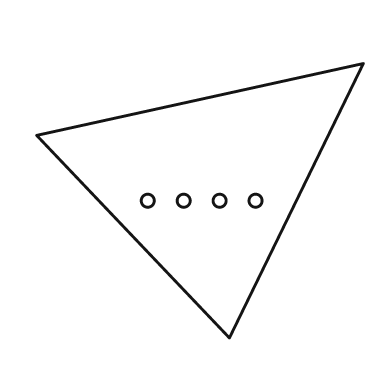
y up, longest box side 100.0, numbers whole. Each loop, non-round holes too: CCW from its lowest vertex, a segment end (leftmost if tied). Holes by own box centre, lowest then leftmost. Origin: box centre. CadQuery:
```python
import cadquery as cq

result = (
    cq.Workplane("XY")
    .moveTo(9.0, -42.0)
    .lineTo(50.0, 42.0)
    .lineTo(-50.0, 20.0)
    .close()
    .moveTo(-16.0, 0.0)
    .circle(2.0)
    .moveTo(-5.0, 0.0)
    .circle(2.0)
    .moveTo(6.0, 0.0)
    .circle(2.0)
    .moveTo(17.0, 0.0)
    .circle(2.0)
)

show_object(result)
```